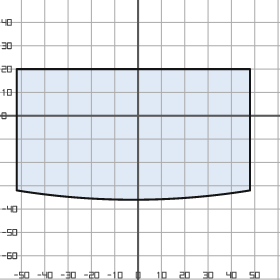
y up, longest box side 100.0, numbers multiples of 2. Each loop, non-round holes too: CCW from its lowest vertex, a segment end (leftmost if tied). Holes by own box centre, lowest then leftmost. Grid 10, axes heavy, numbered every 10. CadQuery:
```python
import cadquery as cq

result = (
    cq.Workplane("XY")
    .moveTo(-52.0, -32.0)
    .threePointArc((-2.0, -36.0), (48.0, -32.0))
    .lineTo(48.0, 20.0)
    .lineTo(-52.0, 20.0)
    .close()
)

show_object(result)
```